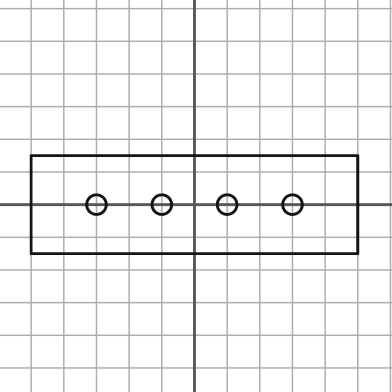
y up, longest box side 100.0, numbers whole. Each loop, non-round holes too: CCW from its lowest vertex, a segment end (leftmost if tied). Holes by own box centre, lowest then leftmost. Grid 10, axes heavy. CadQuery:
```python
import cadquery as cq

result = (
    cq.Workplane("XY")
    .moveTo(-50.0, -15.0)
    .lineTo(50.0, -15.0)
    .lineTo(50.0, 15.0)
    .lineTo(-50.0, 15.0)
    .close()
    .moveTo(-30.0, 0.0)
    .circle(3.0)
    .moveTo(-10.0, 0.0)
    .circle(3.0)
    .moveTo(10.0, 0.0)
    .circle(3.0)
    .moveTo(30.0, 0.0)
    .circle(3.0)
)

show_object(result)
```